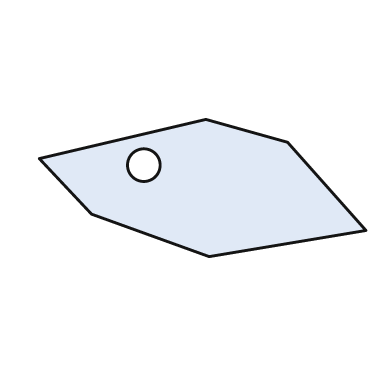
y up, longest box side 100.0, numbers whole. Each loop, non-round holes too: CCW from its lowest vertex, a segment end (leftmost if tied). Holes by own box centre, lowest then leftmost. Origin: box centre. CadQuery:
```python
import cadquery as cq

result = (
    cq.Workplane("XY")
    .moveTo(2.0, -21.0)
    .lineTo(50.0, -13.0)
    .lineTo(26.0, 14.0)
    .lineTo(1.0, 21.0)
    .lineTo(-50.0, 9.0)
    .lineTo(-34.0, -8.0)
    .close()
    .moveTo(-18.0, 7.0)
    .circle(5.0)
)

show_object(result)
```